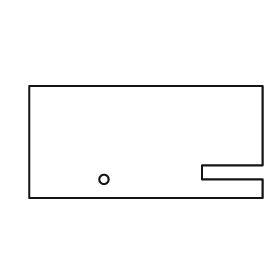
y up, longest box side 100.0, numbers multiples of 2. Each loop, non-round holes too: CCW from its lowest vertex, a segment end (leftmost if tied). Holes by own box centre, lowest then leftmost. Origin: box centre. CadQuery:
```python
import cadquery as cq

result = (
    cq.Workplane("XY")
    .moveTo(-50.0, -24.0)
    .lineTo(50.0, -24.0)
    .lineTo(50.0, -16.0)
    .lineTo(24.0, -16.0)
    .lineTo(24.0, -10.0)
    .lineTo(50.0, -10.0)
    .lineTo(50.0, 24.0)
    .lineTo(-50.0, 24.0)
    .close()
    .moveTo(-18.0, -16.0)
    .circle(2.0)
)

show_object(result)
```